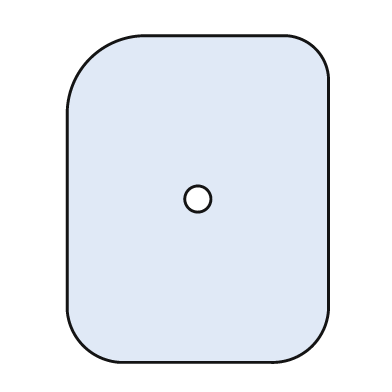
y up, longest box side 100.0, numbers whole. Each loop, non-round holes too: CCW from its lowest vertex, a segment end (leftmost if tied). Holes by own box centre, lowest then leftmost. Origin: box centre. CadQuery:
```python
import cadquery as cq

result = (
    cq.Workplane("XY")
    .moveTo(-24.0, -50.0)
    .lineTo(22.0, -50.0)
    .threePointArc((35.0, -45.0), (40.0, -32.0))
    .lineTo(40.0, 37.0)
    .threePointArc((36.0, 46.0), (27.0, 50.0))
    .lineTo(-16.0, 50.0)
    .threePointArc((-33.0, 43.0), (-40.0, 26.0))
    .lineTo(-40.0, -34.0)
    .threePointArc((-35.0, -45.0), (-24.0, -50.0))
    .close()
    .moveTo(0.0, 0.0)
    .circle(4.0)
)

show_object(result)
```